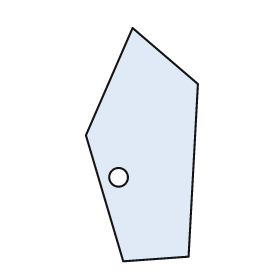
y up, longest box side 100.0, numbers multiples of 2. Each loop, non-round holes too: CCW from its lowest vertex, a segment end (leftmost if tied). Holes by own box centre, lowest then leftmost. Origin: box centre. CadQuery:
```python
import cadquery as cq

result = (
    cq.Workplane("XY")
    .moveTo(-8.0, -50.0)
    .lineTo(20.0, -48.0)
    .lineTo(24.0, 26.0)
    .lineTo(-4.0, 50.0)
    .lineTo(-24.0, 4.0)
    .close()
    .moveTo(-10.0, -14.0)
    .circle(4.0)
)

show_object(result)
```